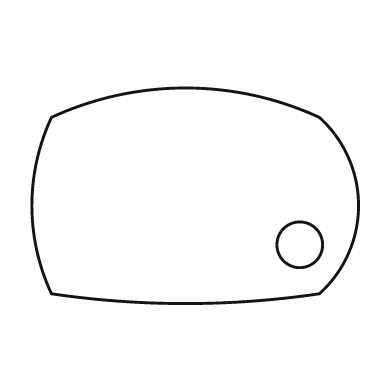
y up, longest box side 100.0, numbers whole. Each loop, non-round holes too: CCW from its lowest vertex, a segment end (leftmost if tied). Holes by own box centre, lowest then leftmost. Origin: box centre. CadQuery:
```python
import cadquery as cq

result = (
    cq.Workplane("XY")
    .moveTo(-44.0, -30.0)
    .threePointArc((-3.0, -33.0), (38.0, -30.0))
    .threePointArc((50.0, -3.0), (38.0, 24.0))
    .threePointArc((-3.0, 33.0), (-44.0, 24.0))
    .threePointArc((-50.0, -3.0), (-44.0, -30.0))
    .close()
    .moveTo(32.0, -15.0)
    .circle(7.0)
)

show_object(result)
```